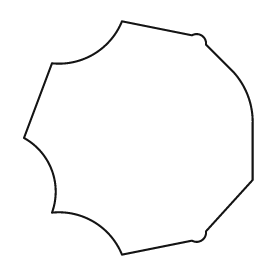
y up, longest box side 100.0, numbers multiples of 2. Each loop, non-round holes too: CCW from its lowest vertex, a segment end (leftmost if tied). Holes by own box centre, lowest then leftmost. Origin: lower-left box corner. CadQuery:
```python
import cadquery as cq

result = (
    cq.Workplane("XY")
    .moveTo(42.0, 0.0)
    .lineTo(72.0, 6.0)
    .threePointArc((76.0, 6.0), (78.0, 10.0))
    .lineTo(98.0, 32.0)
    .lineTo(98.0, 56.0)
    .threePointArc((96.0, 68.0), (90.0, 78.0))
    .lineTo(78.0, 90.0)
    .threePointArc((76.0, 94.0), (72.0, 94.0))
    .lineTo(42.0, 100.0)
    .threePointArc((30.0, 86.0), (12.0, 82.0))
    .lineTo(0.0, 50.0)
    .threePointArc((12.0, 36.0), (12.0, 18.0))
    .threePointArc((30.0, 14.0), (42.0, 0.0))
    .close()
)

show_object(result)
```